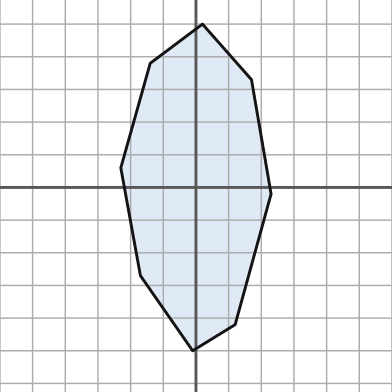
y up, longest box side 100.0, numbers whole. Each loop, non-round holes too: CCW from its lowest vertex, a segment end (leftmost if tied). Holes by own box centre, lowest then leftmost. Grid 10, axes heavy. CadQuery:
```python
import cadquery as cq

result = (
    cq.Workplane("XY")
    .moveTo(-1.0, -50.0)
    .lineTo(12.0, -42.0)
    .lineTo(23.0, -2.0)
    .lineTo(17.0, 33.0)
    .lineTo(2.0, 50.0)
    .lineTo(-14.0, 38.0)
    .lineTo(-23.0, 6.0)
    .lineTo(-17.0, -27.0)
    .close()
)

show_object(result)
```